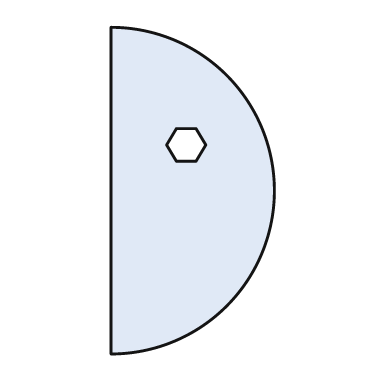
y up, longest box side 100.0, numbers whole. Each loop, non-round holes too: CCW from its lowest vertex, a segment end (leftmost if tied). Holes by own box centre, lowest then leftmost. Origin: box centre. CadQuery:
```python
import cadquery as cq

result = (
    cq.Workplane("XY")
    .moveTo(-25.0, -50.0)
    .threePointArc((25.0, 0.0), (-25.0, 50.0))
    .close()
    .moveTo(-5.0, 9.0)
    .lineTo(1.0, 9.0)
    .lineTo(4.0, 14.0)
    .lineTo(1.0, 19.0)
    .lineTo(-5.0, 19.0)
    .lineTo(-8.0, 14.0)
    .close()
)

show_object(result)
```